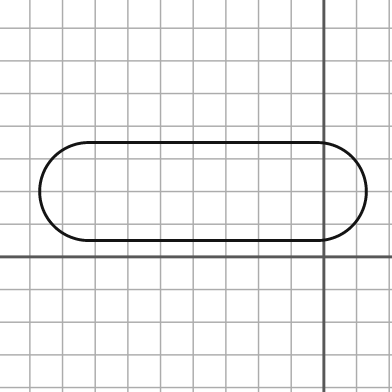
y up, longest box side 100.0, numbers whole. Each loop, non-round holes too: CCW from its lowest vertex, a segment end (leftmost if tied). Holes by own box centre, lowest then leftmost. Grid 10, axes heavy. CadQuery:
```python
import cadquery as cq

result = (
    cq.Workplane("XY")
    .moveTo(-72.0, 5.0)
    .lineTo(-2.0, 5.0)
    .threePointArc((13.0, 20.0), (-2.0, 35.0))
    .lineTo(-72.0, 35.0)
    .threePointArc((-87.0, 20.0), (-72.0, 5.0))
    .close()
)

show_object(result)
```